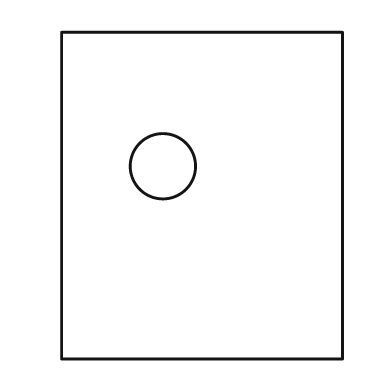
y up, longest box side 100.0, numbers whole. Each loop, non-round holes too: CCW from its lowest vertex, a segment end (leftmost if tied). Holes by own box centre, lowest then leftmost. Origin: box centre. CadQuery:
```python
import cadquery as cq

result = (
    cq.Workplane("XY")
    .moveTo(-43.0, -50.0)
    .lineTo(43.0, -50.0)
    .lineTo(43.0, 50.0)
    .lineTo(-43.0, 50.0)
    .close()
    .moveTo(-12.0, 9.0)
    .circle(10.0)
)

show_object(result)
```